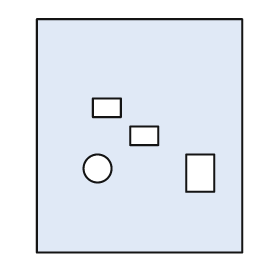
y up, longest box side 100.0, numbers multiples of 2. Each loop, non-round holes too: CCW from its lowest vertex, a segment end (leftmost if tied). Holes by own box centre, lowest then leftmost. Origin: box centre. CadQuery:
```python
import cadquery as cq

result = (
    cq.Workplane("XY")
    .moveTo(-44.0, -50.0)
    .lineTo(44.0, -50.0)
    .lineTo(44.0, 50.0)
    .lineTo(-44.0, 50.0)
    .close()
    .moveTo(20.0, -24.0)
    .lineTo(32.0, -24.0)
    .lineTo(32.0, -8.0)
    .lineTo(20.0, -8.0)
    .close()
    .moveTo(-18.0, -14.0)
    .circle(6.0)
    .moveTo(-4.0, -4.0)
    .lineTo(8.0, -4.0)
    .lineTo(8.0, 4.0)
    .lineTo(-4.0, 4.0)
    .close()
    .moveTo(-20.0, 8.0)
    .lineTo(-8.0, 8.0)
    .lineTo(-8.0, 16.0)
    .lineTo(-20.0, 16.0)
    .close()
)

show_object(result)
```